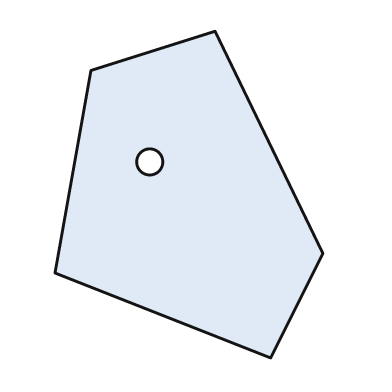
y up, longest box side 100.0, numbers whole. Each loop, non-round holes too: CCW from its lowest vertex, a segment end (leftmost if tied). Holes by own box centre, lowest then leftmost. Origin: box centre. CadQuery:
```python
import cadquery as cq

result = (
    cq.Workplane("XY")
    .moveTo(25.0, -50.0)
    .lineTo(41.0, -18.0)
    .lineTo(8.0, 50.0)
    .lineTo(-30.0, 38.0)
    .lineTo(-41.0, -24.0)
    .close()
    .moveTo(-12.0, 10.0)
    .circle(4.0)
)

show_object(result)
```